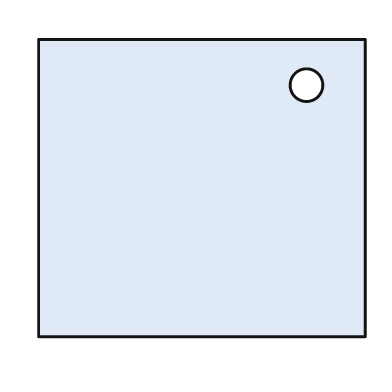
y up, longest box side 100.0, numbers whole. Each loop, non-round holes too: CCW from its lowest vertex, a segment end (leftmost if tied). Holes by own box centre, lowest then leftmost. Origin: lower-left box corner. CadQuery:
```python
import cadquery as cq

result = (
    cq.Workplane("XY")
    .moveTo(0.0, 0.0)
    .lineTo(100.0, 0.0)
    .lineTo(100.0, 91.0)
    .lineTo(0.0, 91.0)
    .close()
    .moveTo(82.0, 77.0)
    .circle(5.0)
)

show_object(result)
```